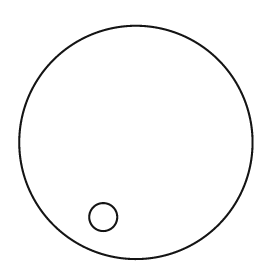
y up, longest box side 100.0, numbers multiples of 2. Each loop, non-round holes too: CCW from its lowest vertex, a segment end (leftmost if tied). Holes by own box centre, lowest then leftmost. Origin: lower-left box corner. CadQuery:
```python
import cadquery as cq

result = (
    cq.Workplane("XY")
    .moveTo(50.0, 50.0)
    .circle(50.0)
    .moveTo(36.0, 18.0)
    .circle(6.0)
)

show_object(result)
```